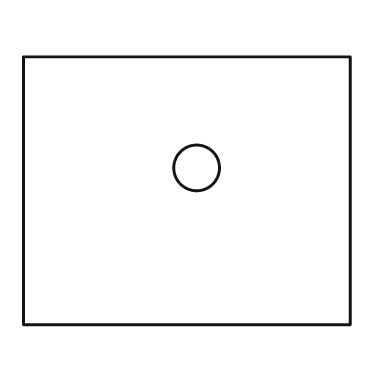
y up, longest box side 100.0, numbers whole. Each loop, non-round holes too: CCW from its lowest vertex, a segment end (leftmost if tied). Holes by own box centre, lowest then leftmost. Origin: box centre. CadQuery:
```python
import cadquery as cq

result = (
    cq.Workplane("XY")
    .moveTo(-50.0, -41.0)
    .lineTo(50.0, -41.0)
    .lineTo(50.0, 41.0)
    .lineTo(-50.0, 41.0)
    .close()
    .moveTo(3.0, 7.0)
    .circle(7.0)
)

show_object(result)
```